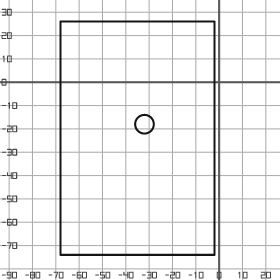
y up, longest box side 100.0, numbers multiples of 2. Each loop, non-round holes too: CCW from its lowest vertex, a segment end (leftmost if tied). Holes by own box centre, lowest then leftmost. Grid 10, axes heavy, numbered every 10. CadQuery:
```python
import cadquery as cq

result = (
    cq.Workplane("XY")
    .moveTo(-68.0, -74.0)
    .lineTo(-2.0, -74.0)
    .lineTo(-2.0, 26.0)
    .lineTo(-68.0, 26.0)
    .close()
    .moveTo(-32.0, -18.0)
    .circle(4.0)
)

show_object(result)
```